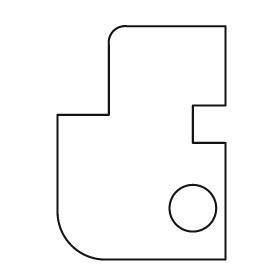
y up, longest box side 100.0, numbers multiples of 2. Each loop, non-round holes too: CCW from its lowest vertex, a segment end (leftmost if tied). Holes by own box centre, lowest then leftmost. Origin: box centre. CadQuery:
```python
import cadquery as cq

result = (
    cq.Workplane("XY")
    .moveTo(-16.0, -50.0)
    .lineTo(36.0, -50.0)
    .lineTo(36.0, 0.0)
    .lineTo(22.0, 0.0)
    .lineTo(22.0, 16.0)
    .lineTo(36.0, 16.0)
    .lineTo(36.0, 50.0)
    .lineTo(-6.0, 50.0)
    .threePointArc((-12.0, 48.0), (-14.0, 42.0))
    .lineTo(-14.0, 12.0)
    .lineTo(-36.0, 12.0)
    .lineTo(-36.0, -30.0)
    .threePointArc((-30.0, -44.0), (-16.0, -50.0))
    .close()
    .moveTo(22.0, -28.0)
    .circle(10.0)
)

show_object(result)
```